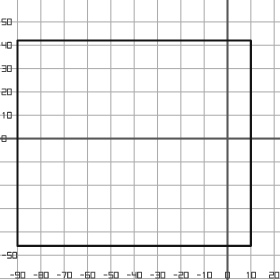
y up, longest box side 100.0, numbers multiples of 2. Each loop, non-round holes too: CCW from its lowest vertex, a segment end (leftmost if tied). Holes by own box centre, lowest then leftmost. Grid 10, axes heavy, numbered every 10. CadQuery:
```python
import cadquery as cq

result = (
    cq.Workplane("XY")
    .moveTo(-90.0, -46.0)
    .lineTo(10.0, -46.0)
    .lineTo(10.0, 42.0)
    .lineTo(-90.0, 42.0)
    .close()
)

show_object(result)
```